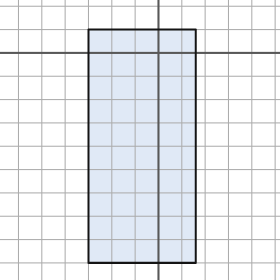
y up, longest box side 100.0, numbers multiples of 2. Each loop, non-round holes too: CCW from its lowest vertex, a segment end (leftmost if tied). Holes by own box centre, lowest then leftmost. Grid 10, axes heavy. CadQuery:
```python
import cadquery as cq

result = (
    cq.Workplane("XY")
    .moveTo(-30.0, -90.0)
    .lineTo(16.0, -90.0)
    .lineTo(16.0, 10.0)
    .lineTo(-30.0, 10.0)
    .close()
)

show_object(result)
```